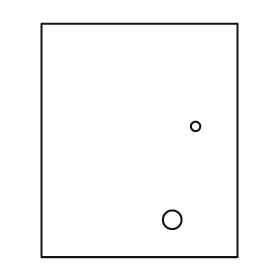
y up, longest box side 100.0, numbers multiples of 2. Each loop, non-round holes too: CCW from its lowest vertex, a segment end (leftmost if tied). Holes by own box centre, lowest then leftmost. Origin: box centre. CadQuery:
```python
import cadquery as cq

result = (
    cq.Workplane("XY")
    .moveTo(-42.0, -50.0)
    .lineTo(42.0, -50.0)
    .lineTo(42.0, 50.0)
    .lineTo(-42.0, 50.0)
    .close()
    .moveTo(14.0, -34.0)
    .circle(4.0)
    .moveTo(24.0, 6.0)
    .circle(2.0)
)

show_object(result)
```